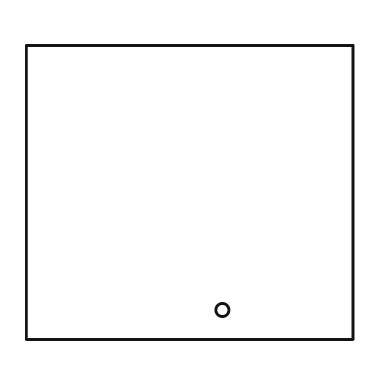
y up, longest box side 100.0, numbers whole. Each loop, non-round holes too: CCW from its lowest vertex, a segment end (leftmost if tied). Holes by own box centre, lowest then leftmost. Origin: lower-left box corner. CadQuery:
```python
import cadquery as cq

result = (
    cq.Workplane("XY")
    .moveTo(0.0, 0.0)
    .lineTo(100.0, 0.0)
    .lineTo(100.0, 90.0)
    .lineTo(0.0, 90.0)
    .close()
    .moveTo(60.0, 9.0)
    .circle(2.0)
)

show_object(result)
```